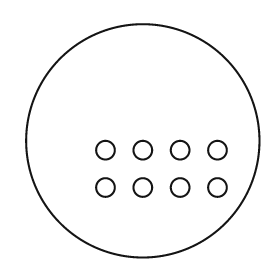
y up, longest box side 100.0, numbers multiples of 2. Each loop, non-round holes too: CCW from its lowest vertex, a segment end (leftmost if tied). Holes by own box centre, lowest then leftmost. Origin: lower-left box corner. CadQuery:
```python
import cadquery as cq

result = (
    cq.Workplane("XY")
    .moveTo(50.0, 50.0)
    .circle(50.0)
    .moveTo(34.0, 30.0)
    .circle(4.0)
    .moveTo(50.0, 30.0)
    .circle(4.0)
    .moveTo(66.0, 30.0)
    .circle(4.0)
    .moveTo(82.0, 30.0)
    .circle(4.0)
    .moveTo(34.0, 46.0)
    .circle(4.0)
    .moveTo(50.0, 46.0)
    .circle(4.0)
    .moveTo(66.0, 46.0)
    .circle(4.0)
    .moveTo(82.0, 46.0)
    .circle(4.0)
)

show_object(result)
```